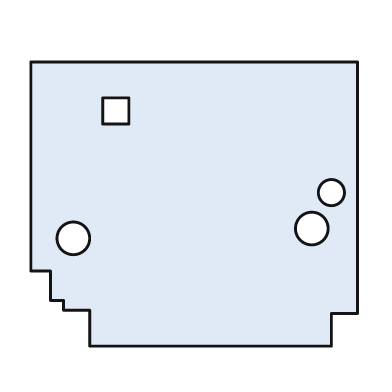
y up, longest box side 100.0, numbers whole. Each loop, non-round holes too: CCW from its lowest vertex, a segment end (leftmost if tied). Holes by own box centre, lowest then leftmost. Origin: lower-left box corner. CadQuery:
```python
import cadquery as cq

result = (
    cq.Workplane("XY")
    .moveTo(18.0, 0.0)
    .lineTo(92.0, 0.0)
    .lineTo(92.0, 10.0)
    .lineTo(100.0, 10.0)
    .lineTo(100.0, 87.0)
    .lineTo(0.0, 87.0)
    .lineTo(0.0, 23.0)
    .lineTo(6.0, 23.0)
    .lineTo(6.0, 14.0)
    .lineTo(10.0, 14.0)
    .lineTo(10.0, 11.0)
    .lineTo(18.0, 11.0)
    .close()
    .moveTo(13.0, 33.0)
    .circle(5.0)
    .moveTo(86.0, 36.0)
    .circle(5.0)
    .moveTo(92.0, 47.0)
    .circle(4.0)
    .moveTo(22.0, 68.0)
    .lineTo(30.0, 68.0)
    .lineTo(30.0, 76.0)
    .lineTo(22.0, 76.0)
    .close()
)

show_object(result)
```